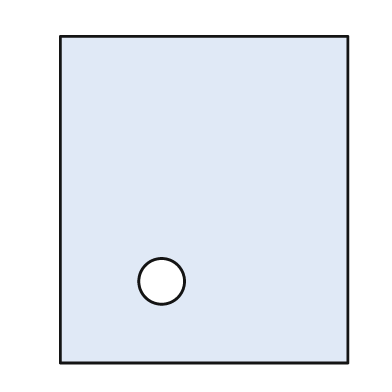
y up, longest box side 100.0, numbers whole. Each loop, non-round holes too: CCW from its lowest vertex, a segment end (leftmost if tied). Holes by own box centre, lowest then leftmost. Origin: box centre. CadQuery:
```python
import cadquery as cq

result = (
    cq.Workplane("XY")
    .moveTo(-44.0, -50.0)
    .lineTo(44.0, -50.0)
    .lineTo(44.0, 50.0)
    .lineTo(-44.0, 50.0)
    .close()
    .moveTo(-13.0, -25.0)
    .circle(7.0)
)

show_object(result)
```